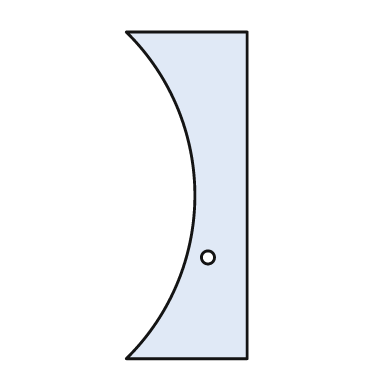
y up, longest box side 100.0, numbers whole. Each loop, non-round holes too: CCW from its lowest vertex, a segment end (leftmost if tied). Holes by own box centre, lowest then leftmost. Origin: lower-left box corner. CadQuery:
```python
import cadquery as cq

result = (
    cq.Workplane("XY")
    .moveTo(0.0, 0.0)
    .lineTo(37.0, 0.0)
    .lineTo(37.0, 100.0)
    .lineTo(0.0, 100.0)
    .threePointArc((21.0, 50.0), (0.0, 0.0))
    .close()
    .moveTo(25.0, 31.0)
    .circle(2.0)
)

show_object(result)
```